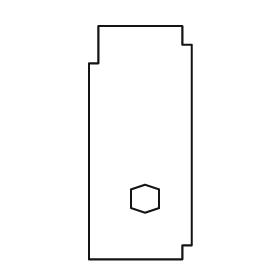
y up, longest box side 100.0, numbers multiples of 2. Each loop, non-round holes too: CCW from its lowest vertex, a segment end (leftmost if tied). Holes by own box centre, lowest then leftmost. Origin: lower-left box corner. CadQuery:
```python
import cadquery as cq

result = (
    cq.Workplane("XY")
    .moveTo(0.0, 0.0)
    .lineTo(40.0, 0.0)
    .lineTo(40.0, 6.0)
    .lineTo(44.0, 6.0)
    .lineTo(44.0, 92.0)
    .lineTo(40.0, 92.0)
    .lineTo(40.0, 100.0)
    .lineTo(4.0, 100.0)
    .lineTo(4.0, 84.0)
    .lineTo(0.0, 84.0)
    .close()
    .moveTo(24.0, 20.0)
    .lineTo(30.0, 22.0)
    .lineTo(30.0, 30.0)
    .lineTo(24.0, 32.0)
    .lineTo(18.0, 30.0)
    .lineTo(18.0, 22.0)
    .close()
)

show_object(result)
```